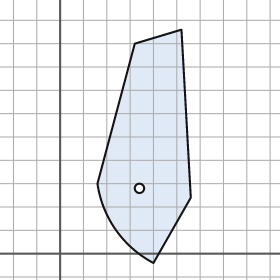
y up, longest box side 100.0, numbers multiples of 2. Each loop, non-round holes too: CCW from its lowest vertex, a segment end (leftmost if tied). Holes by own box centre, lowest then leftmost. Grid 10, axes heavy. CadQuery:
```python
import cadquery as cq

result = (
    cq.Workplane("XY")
    .moveTo(40.0, -4.0)
    .lineTo(56.0, 24.0)
    .lineTo(52.0, 96.0)
    .lineTo(32.0, 90.0)
    .lineTo(16.0, 30.0)
    .threePointArc((24.0, 10.0), (40.0, -4.0))
    .close()
    .moveTo(34.0, 28.0)
    .circle(2.0)
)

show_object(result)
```